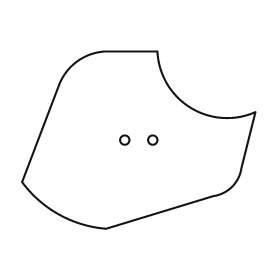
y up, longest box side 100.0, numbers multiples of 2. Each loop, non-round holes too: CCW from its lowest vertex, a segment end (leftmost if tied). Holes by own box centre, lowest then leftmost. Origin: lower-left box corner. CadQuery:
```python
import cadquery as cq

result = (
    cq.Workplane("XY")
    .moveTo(36.0, 0.0)
    .lineTo(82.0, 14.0)
    .threePointArc((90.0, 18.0), (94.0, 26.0))
    .lineTo(100.0, 50.0)
    .threePointArc((72.0, 52.0), (58.0, 76.0))
    .lineTo(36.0, 76.0)
    .threePointArc((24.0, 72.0), (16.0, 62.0))
    .lineTo(0.0, 20.0)
    .threePointArc((16.0, 6.0), (36.0, 0.0))
    .close()
    .moveTo(44.0, 38.0)
    .circle(2.0)
    .moveTo(56.0, 38.0)
    .circle(2.0)
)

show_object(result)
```